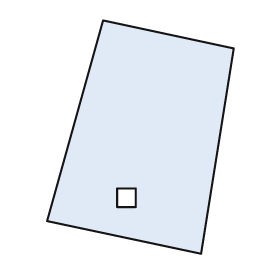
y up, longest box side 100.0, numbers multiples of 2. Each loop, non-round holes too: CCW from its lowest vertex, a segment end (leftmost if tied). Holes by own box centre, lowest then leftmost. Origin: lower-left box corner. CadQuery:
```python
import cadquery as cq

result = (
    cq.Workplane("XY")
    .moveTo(66.0, 0.0)
    .lineTo(80.0, 88.0)
    .lineTo(24.0, 100.0)
    .lineTo(0.0, 14.0)
    .close()
    .moveTo(30.0, 20.0)
    .lineTo(38.0, 20.0)
    .lineTo(38.0, 28.0)
    .lineTo(30.0, 28.0)
    .close()
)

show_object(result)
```